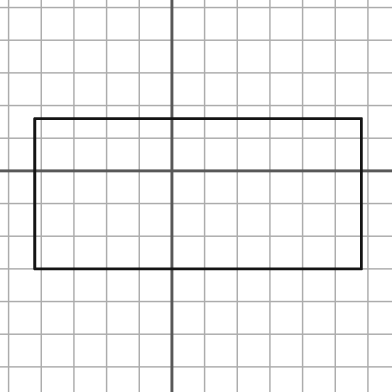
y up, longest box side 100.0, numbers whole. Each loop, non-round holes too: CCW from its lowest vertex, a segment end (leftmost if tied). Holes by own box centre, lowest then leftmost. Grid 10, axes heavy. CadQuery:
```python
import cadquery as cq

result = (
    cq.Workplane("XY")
    .moveTo(-42.0, -30.0)
    .lineTo(58.0, -30.0)
    .lineTo(58.0, 16.0)
    .lineTo(-42.0, 16.0)
    .close()
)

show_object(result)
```